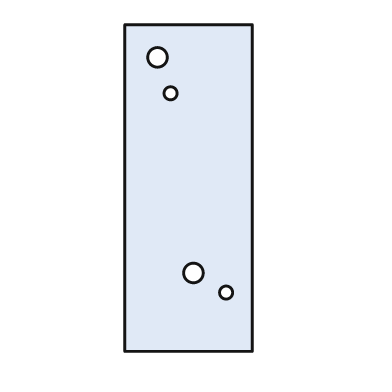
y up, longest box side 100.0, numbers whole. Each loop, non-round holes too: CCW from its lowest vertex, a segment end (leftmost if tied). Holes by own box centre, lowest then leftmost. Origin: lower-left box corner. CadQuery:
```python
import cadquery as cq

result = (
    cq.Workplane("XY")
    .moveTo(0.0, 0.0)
    .lineTo(39.0, 0.0)
    .lineTo(39.0, 100.0)
    .lineTo(0.0, 100.0)
    .close()
    .moveTo(31.0, 18.0)
    .circle(2.0)
    .moveTo(21.0, 24.0)
    .circle(3.0)
    .moveTo(14.0, 79.0)
    .circle(2.0)
    .moveTo(10.0, 90.0)
    .circle(3.0)
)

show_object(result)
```